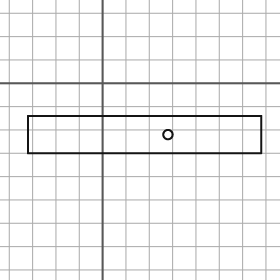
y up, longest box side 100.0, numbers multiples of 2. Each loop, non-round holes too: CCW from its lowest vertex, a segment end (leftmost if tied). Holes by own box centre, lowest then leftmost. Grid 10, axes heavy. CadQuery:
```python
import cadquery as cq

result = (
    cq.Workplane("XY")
    .moveTo(-32.0, -30.0)
    .lineTo(68.0, -30.0)
    .lineTo(68.0, -14.0)
    .lineTo(-32.0, -14.0)
    .close()
    .moveTo(28.0, -22.0)
    .circle(2.0)
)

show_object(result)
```